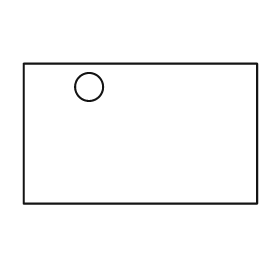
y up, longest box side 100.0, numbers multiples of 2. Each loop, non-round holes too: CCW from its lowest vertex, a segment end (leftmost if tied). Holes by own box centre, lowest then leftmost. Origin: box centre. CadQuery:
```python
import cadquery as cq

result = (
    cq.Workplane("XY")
    .moveTo(-50.0, -30.0)
    .lineTo(50.0, -30.0)
    .lineTo(50.0, 30.0)
    .lineTo(-50.0, 30.0)
    .close()
    .moveTo(-22.0, 20.0)
    .circle(6.0)
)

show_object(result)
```